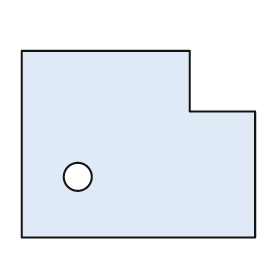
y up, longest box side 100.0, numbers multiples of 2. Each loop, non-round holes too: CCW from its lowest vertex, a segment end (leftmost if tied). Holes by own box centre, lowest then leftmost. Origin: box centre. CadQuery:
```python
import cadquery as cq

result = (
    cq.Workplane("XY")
    .moveTo(-50.0, -40.0)
    .lineTo(50.0, -40.0)
    .lineTo(50.0, 14.0)
    .lineTo(22.0, 14.0)
    .lineTo(22.0, 40.0)
    .lineTo(-50.0, 40.0)
    .close()
    .moveTo(-26.0, -14.0)
    .circle(6.0)
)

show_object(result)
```